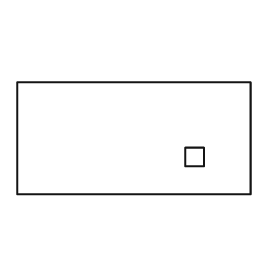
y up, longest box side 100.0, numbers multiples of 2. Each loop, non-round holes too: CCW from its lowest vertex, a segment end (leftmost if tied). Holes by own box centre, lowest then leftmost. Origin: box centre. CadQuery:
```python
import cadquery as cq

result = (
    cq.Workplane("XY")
    .moveTo(-50.0, -24.0)
    .lineTo(50.0, -24.0)
    .lineTo(50.0, 24.0)
    .lineTo(-50.0, 24.0)
    .close()
    .moveTo(22.0, -12.0)
    .lineTo(30.0, -12.0)
    .lineTo(30.0, -4.0)
    .lineTo(22.0, -4.0)
    .close()
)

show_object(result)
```